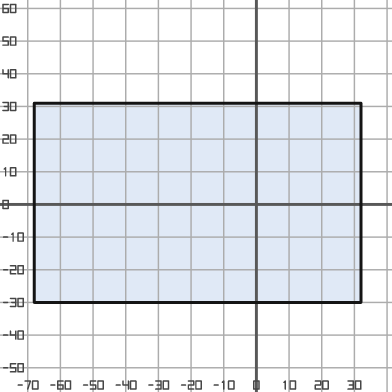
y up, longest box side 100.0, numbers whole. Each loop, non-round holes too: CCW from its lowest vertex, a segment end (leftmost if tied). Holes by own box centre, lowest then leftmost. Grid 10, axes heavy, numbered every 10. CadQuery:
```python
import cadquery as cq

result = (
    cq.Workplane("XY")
    .moveTo(-68.0, -30.0)
    .lineTo(32.0, -30.0)
    .lineTo(32.0, 31.0)
    .lineTo(-68.0, 31.0)
    .close()
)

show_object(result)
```